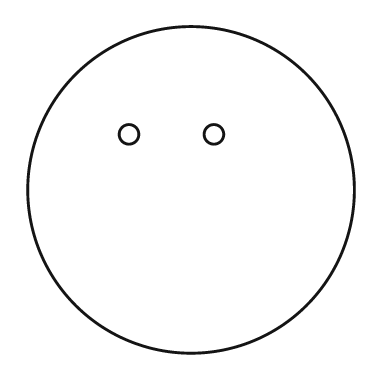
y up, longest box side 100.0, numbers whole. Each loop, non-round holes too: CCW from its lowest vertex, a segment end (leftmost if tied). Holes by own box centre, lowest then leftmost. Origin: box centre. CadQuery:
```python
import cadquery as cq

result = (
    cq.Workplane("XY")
    .moveTo(0.0, 0.0)
    .circle(50.0)
    .moveTo(-19.0, 17.0)
    .circle(3.0)
    .moveTo(7.0, 17.0)
    .circle(3.0)
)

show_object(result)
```